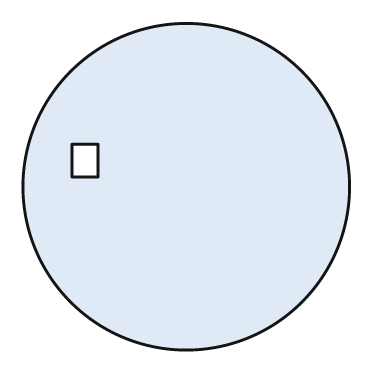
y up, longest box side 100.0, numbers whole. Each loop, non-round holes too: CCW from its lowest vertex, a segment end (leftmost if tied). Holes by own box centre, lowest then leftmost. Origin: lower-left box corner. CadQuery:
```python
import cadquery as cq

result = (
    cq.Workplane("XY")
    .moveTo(50.0, 50.0)
    .circle(50.0)
    .moveTo(15.0, 53.0)
    .lineTo(23.0, 53.0)
    .lineTo(23.0, 63.0)
    .lineTo(15.0, 63.0)
    .close()
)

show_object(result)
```